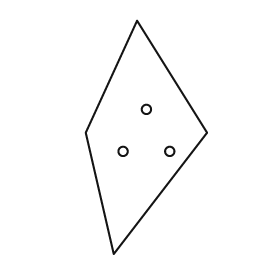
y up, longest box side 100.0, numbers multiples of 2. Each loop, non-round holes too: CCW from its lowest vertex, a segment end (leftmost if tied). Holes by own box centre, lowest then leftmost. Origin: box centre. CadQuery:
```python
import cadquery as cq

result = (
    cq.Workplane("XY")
    .moveTo(-14.0, -50.0)
    .lineTo(26.0, 2.0)
    .lineTo(-4.0, 50.0)
    .lineTo(-26.0, 2.0)
    .close()
    .moveTo(-10.0, -6.0)
    .circle(2.0)
    .moveTo(10.0, -6.0)
    .circle(2.0)
    .moveTo(0.0, 12.0)
    .circle(2.0)
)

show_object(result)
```